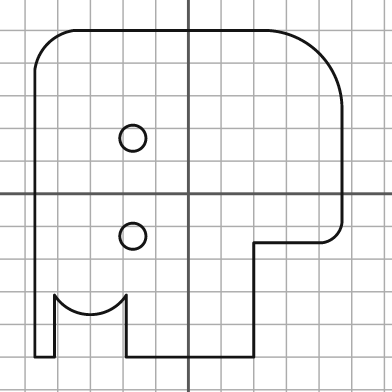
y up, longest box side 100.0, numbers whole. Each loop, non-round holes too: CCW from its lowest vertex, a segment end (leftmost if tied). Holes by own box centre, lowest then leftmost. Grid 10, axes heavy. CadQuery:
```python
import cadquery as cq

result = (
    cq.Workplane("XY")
    .moveTo(-47.0, -50.0)
    .lineTo(-41.0, -50.0)
    .lineTo(-41.0, -31.0)
    .threePointArc((-30.0, -37.0), (-19.0, -31.0))
    .lineTo(-19.0, -50.0)
    .lineTo(20.0, -50.0)
    .lineTo(20.0, -15.0)
    .lineTo(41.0, -15.0)
    .threePointArc((45.0, -13.0), (47.0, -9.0))
    .lineTo(47.0, 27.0)
    .threePointArc((40.0, 43.0), (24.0, 50.0))
    .lineTo(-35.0, 50.0)
    .threePointArc((-43.0, 46.0), (-47.0, 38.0))
    .close()
    .moveTo(-17.0, -13.0)
    .circle(4.0)
    .moveTo(-17.0, 17.0)
    .circle(4.0)
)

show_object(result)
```